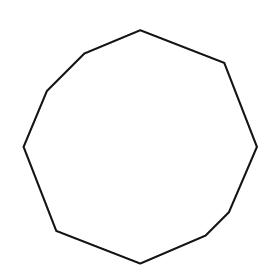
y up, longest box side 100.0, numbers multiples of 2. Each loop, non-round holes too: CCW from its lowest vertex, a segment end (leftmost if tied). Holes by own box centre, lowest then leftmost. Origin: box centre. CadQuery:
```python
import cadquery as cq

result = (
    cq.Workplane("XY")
    .moveTo(0.0, -50.0)
    .lineTo(28.0, -38.0)
    .lineTo(38.0, -28.0)
    .lineTo(50.0, 0.0)
    .lineTo(36.0, 36.0)
    .lineTo(0.0, 50.0)
    .lineTo(-24.0, 40.0)
    .lineTo(-40.0, 24.0)
    .lineTo(-50.0, 0.0)
    .lineTo(-36.0, -36.0)
    .close()
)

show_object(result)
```